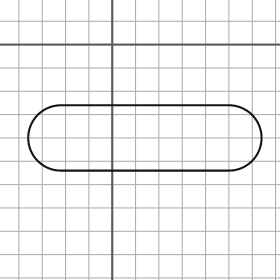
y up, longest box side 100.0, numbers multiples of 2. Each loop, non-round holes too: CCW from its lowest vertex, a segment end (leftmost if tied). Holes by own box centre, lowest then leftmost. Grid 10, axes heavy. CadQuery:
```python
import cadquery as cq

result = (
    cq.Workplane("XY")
    .moveTo(-22.0, -54.0)
    .lineTo(50.0, -54.0)
    .threePointArc((64.0, -40.0), (50.0, -26.0))
    .lineTo(-22.0, -26.0)
    .threePointArc((-36.0, -40.0), (-22.0, -54.0))
    .close()
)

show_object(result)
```